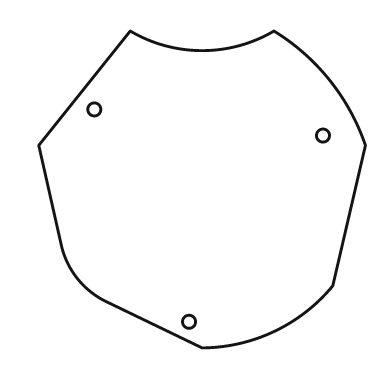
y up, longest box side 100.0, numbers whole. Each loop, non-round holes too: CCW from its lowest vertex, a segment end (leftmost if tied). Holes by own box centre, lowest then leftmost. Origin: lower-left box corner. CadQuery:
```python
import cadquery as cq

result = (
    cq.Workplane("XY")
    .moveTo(50.0, 0.0)
    .threePointArc((72.0, 5.0), (90.0, 19.0))
    .lineTo(100.0, 62.0)
    .threePointArc((89.0, 82.0), (72.0, 97.0))
    .threePointArc((50.0, 91.0), (28.0, 97.0))
    .lineTo(0.0, 62.0)
    .lineTo(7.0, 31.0)
    .threePointArc((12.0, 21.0), (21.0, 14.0))
    .close()
    .moveTo(46.0, 8.0)
    .circle(2.0)
    .moveTo(87.0, 65.0)
    .circle(2.0)
    .moveTo(17.0, 73.0)
    .circle(2.0)
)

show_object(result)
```